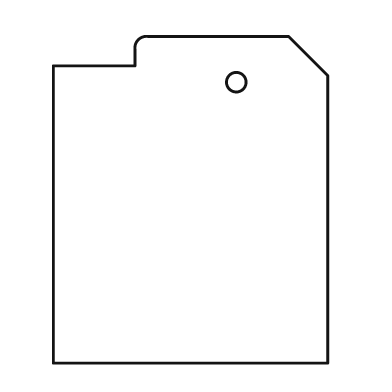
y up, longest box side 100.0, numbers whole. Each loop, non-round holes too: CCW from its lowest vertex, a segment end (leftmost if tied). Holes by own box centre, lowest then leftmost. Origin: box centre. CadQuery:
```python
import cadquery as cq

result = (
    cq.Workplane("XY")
    .moveTo(-42.0, -50.0)
    .lineTo(42.0, -50.0)
    .lineTo(42.0, 38.0)
    .lineTo(30.0, 50.0)
    .lineTo(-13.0, 50.0)
    .threePointArc((-16.0, 49.0), (-17.0, 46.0))
    .lineTo(-17.0, 41.0)
    .lineTo(-42.0, 41.0)
    .close()
    .moveTo(14.0, 36.0)
    .circle(3.0)
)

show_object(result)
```